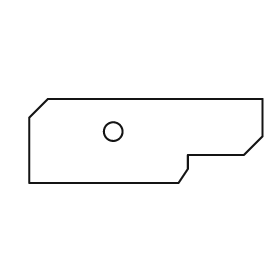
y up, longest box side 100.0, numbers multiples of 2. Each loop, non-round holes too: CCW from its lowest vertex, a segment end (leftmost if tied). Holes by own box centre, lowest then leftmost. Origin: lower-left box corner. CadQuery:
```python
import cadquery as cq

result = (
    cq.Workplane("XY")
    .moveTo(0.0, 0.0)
    .lineTo(64.0, 0.0)
    .lineTo(68.0, 6.0)
    .lineTo(68.0, 12.0)
    .lineTo(92.0, 12.0)
    .lineTo(100.0, 20.0)
    .lineTo(100.0, 36.0)
    .lineTo(8.0, 36.0)
    .lineTo(0.0, 28.0)
    .close()
    .moveTo(36.0, 22.0)
    .circle(4.0)
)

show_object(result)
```